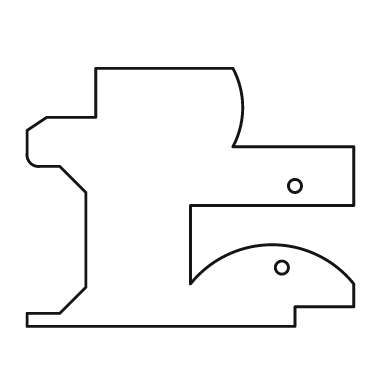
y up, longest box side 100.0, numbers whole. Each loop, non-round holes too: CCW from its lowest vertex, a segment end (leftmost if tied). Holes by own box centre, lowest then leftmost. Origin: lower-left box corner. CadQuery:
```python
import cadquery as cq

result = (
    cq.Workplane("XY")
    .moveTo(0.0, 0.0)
    .lineTo(82.0, 0.0)
    .lineTo(82.0, 6.0)
    .lineTo(100.0, 6.0)
    .lineTo(100.0, 13.0)
    .threePointArc((75.0, 25.0), (50.0, 13.0))
    .lineTo(50.0, 37.0)
    .lineTo(100.0, 37.0)
    .lineTo(100.0, 55.0)
    .lineTo(63.0, 55.0)
    .threePointArc((66.0, 67.0), (63.0, 79.0))
    .lineTo(21.0, 79.0)
    .lineTo(21.0, 64.0)
    .lineTo(6.0, 64.0)
    .lineTo(0.0, 60.0)
    .lineTo(0.0, 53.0)
    .threePointArc((1.0, 50.0), (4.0, 49.0))
    .lineTo(10.0, 49.0)
    .lineTo(18.0, 41.0)
    .lineTo(18.0, 12.0)
    .lineTo(10.0, 4.0)
    .lineTo(0.0, 4.0)
    .close()
    .moveTo(78.0, 18.0)
    .circle(2.0)
    .moveTo(82.0, 43.0)
    .circle(2.0)
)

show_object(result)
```